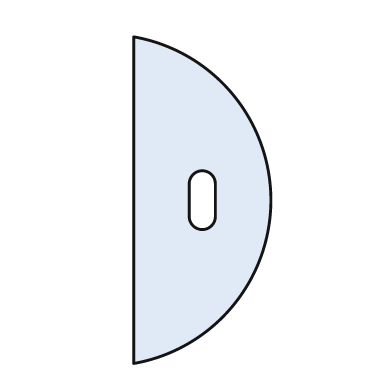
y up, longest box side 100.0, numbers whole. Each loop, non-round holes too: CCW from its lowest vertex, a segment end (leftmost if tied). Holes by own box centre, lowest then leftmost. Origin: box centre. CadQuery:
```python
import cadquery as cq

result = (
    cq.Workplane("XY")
    .moveTo(-21.0, -50.0)
    .threePointArc((21.0, 0.0), (-21.0, 50.0))
    .close()
    .moveTo(-4.0, -5.0)
    .threePointArc((0.0, -9.0), (4.0, -5.0))
    .lineTo(4.0, 5.0)
    .threePointArc((0.0, 9.0), (-4.0, 5.0))
    .close()
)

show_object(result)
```